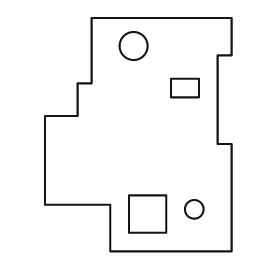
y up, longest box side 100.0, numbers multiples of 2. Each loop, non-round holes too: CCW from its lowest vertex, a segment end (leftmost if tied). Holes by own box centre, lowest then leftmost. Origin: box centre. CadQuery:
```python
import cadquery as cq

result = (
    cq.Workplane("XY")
    .moveTo(-12.0, -50.0)
    .lineTo(40.0, -50.0)
    .lineTo(40.0, -4.0)
    .lineTo(34.0, -4.0)
    .lineTo(34.0, 34.0)
    .lineTo(40.0, 34.0)
    .lineTo(40.0, 50.0)
    .lineTo(-20.0, 50.0)
    .lineTo(-20.0, 22.0)
    .lineTo(-26.0, 22.0)
    .lineTo(-26.0, 8.0)
    .lineTo(-40.0, 8.0)
    .lineTo(-40.0, -30.0)
    .lineTo(-12.0, -30.0)
    .close()
    .moveTo(-4.0, -42.0)
    .lineTo(12.0, -42.0)
    .lineTo(12.0, -26.0)
    .lineTo(-4.0, -26.0)
    .close()
    .moveTo(24.0, -32.0)
    .circle(4.0)
    .moveTo(14.0, 16.0)
    .lineTo(26.0, 16.0)
    .lineTo(26.0, 24.0)
    .lineTo(14.0, 24.0)
    .close()
    .moveTo(-2.0, 38.0)
    .circle(6.0)
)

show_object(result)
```